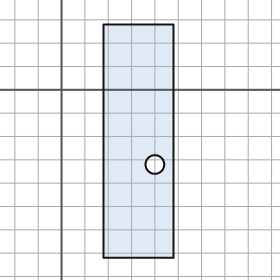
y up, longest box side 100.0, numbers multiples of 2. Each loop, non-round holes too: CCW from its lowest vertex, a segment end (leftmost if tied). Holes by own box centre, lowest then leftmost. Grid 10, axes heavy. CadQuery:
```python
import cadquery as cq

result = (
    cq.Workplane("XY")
    .moveTo(18.0, -72.0)
    .lineTo(48.0, -72.0)
    .lineTo(48.0, 28.0)
    .lineTo(18.0, 28.0)
    .close()
    .moveTo(40.0, -32.0)
    .circle(4.0)
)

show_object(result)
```